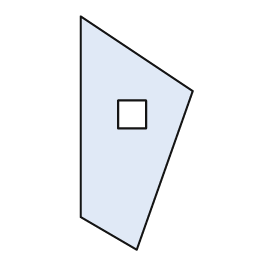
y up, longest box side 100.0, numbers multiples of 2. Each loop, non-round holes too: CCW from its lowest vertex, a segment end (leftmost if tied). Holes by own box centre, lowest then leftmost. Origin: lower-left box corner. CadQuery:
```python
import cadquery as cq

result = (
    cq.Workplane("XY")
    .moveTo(24.0, 0.0)
    .lineTo(48.0, 68.0)
    .lineTo(0.0, 100.0)
    .lineTo(0.0, 14.0)
    .close()
    .moveTo(16.0, 52.0)
    .lineTo(28.0, 52.0)
    .lineTo(28.0, 64.0)
    .lineTo(16.0, 64.0)
    .close()
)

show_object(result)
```